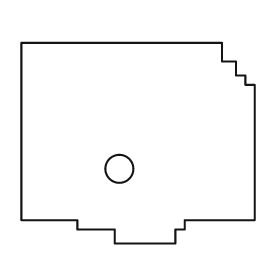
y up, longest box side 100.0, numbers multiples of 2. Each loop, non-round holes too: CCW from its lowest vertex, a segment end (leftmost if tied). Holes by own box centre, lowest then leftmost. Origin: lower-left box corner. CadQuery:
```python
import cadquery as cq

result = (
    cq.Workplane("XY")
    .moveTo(40.0, 0.0)
    .lineTo(66.0, 0.0)
    .lineTo(66.0, 6.0)
    .lineTo(70.0, 6.0)
    .lineTo(70.0, 10.0)
    .lineTo(100.0, 10.0)
    .lineTo(100.0, 68.0)
    .lineTo(96.0, 68.0)
    .lineTo(96.0, 72.0)
    .lineTo(92.0, 72.0)
    .lineTo(92.0, 78.0)
    .lineTo(86.0, 78.0)
    .lineTo(86.0, 86.0)
    .lineTo(0.0, 86.0)
    .lineTo(0.0, 10.0)
    .lineTo(24.0, 10.0)
    .lineTo(24.0, 6.0)
    .lineTo(40.0, 6.0)
    .close()
    .moveTo(42.0, 32.0)
    .circle(6.0)
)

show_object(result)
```